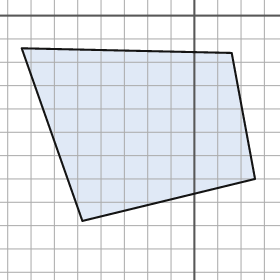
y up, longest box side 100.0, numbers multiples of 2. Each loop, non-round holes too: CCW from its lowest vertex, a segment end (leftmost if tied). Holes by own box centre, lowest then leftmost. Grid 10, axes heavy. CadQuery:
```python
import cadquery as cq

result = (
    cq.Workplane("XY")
    .moveTo(-48.0, -88.0)
    .lineTo(26.0, -70.0)
    .lineTo(16.0, -16.0)
    .lineTo(-74.0, -14.0)
    .close()
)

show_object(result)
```